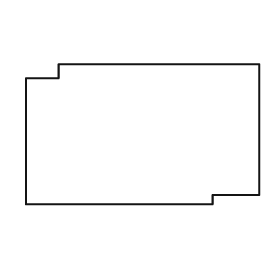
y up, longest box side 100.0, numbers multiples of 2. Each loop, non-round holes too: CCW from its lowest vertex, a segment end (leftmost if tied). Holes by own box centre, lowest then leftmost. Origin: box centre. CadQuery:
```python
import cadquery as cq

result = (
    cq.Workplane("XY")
    .moveTo(-50.0, -30.0)
    .lineTo(30.0, -30.0)
    .lineTo(30.0, -26.0)
    .lineTo(50.0, -26.0)
    .lineTo(50.0, 30.0)
    .lineTo(-36.0, 30.0)
    .lineTo(-36.0, 24.0)
    .lineTo(-50.0, 24.0)
    .close()
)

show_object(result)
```